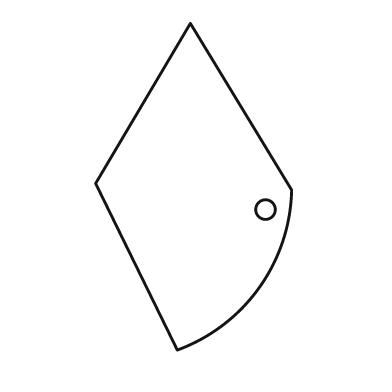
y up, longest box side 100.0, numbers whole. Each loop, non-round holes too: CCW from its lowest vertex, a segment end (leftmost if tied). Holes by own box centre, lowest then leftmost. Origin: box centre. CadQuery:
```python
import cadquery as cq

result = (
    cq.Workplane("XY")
    .moveTo(-5.0, -50.0)
    .threePointArc((20.0, -31.0), (30.0, -1.0))
    .lineTo(-1.0, 50.0)
    .lineTo(-30.0, 1.0)
    .close()
    .moveTo(22.0, -7.0)
    .circle(3.0)
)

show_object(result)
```